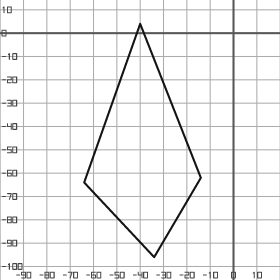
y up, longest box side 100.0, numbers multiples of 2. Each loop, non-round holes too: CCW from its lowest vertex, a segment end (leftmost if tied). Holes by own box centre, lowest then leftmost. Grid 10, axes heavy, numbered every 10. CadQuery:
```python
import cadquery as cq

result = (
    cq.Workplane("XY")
    .moveTo(-34.0, -96.0)
    .lineTo(-14.0, -62.0)
    .lineTo(-40.0, 4.0)
    .lineTo(-64.0, -64.0)
    .close()
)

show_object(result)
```